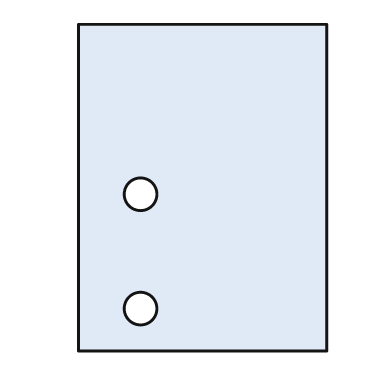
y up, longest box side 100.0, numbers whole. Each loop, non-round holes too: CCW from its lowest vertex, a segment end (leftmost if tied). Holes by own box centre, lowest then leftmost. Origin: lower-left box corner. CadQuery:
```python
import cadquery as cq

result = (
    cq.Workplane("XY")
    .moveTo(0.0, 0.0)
    .lineTo(76.0, 0.0)
    .lineTo(76.0, 100.0)
    .lineTo(0.0, 100.0)
    .close()
    .moveTo(19.0, 13.0)
    .circle(5.0)
    .moveTo(19.0, 48.0)
    .circle(5.0)
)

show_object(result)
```